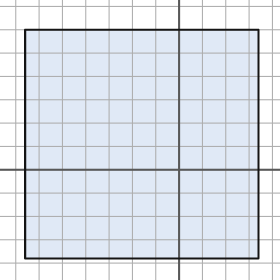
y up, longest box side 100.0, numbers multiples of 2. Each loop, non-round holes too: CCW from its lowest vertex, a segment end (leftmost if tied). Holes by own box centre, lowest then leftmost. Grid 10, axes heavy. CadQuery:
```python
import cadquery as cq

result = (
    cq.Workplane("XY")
    .moveTo(-66.0, -38.0)
    .lineTo(34.0, -38.0)
    .lineTo(34.0, 60.0)
    .lineTo(-66.0, 60.0)
    .close()
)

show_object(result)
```